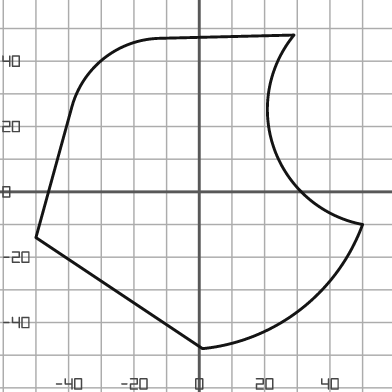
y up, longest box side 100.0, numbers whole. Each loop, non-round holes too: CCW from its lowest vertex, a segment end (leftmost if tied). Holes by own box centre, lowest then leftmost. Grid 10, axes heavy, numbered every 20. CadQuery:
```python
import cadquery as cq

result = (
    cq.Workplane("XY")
    .moveTo(1.0, -48.0)
    .threePointArc((31.0, -36.0), (50.0, -10.0))
    .threePointArc((23.0, 13.0), (29.0, 48.0))
    .lineTo(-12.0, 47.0)
    .threePointArc((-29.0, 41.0), (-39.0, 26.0))
    .lineTo(-50.0, -14.0)
    .close()
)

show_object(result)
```